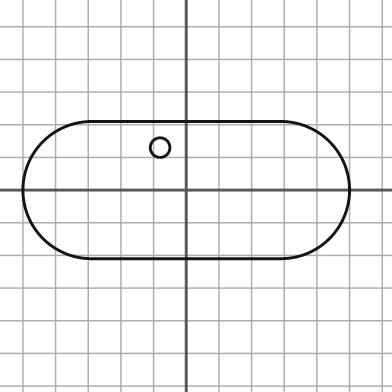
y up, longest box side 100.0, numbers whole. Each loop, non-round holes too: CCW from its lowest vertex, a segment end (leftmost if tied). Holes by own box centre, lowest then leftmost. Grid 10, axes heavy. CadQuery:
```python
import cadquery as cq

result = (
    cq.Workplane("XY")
    .moveTo(-29.0, -21.0)
    .lineTo(29.0, -21.0)
    .threePointArc((50.0, 0.0), (29.0, 21.0))
    .lineTo(-29.0, 21.0)
    .threePointArc((-50.0, 0.0), (-29.0, -21.0))
    .close()
    .moveTo(-8.0, 13.0)
    .circle(3.0)
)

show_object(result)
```